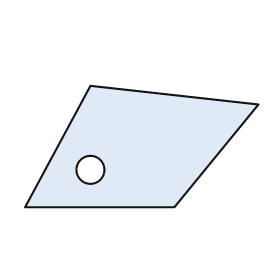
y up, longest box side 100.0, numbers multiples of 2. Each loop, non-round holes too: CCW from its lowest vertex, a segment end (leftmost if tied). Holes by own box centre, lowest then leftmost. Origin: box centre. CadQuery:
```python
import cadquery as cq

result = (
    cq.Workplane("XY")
    .moveTo(-50.0, -26.0)
    .lineTo(14.0, -26.0)
    .lineTo(50.0, 18.0)
    .lineTo(-22.0, 26.0)
    .close()
    .moveTo(-22.0, -10.0)
    .circle(6.0)
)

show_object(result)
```